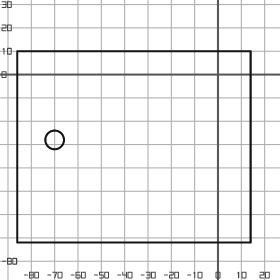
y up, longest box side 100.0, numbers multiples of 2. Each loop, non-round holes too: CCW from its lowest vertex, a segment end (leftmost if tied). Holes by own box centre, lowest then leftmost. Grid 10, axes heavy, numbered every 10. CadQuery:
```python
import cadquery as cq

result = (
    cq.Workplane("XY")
    .moveTo(-86.0, -72.0)
    .lineTo(14.0, -72.0)
    .lineTo(14.0, 10.0)
    .lineTo(-86.0, 10.0)
    .close()
    .moveTo(-70.0, -28.0)
    .circle(4.0)
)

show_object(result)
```